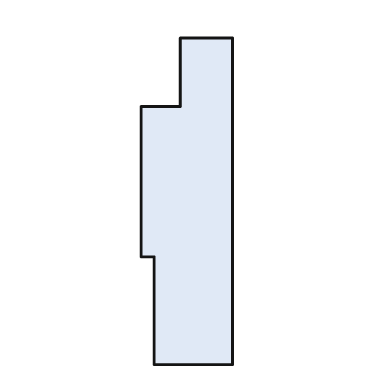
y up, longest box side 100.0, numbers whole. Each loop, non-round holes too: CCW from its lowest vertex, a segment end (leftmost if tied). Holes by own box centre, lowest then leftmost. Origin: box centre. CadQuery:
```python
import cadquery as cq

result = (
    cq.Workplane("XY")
    .moveTo(-10.0, -50.0)
    .lineTo(14.0, -50.0)
    .lineTo(14.0, 50.0)
    .lineTo(-2.0, 50.0)
    .lineTo(-2.0, 29.0)
    .lineTo(-14.0, 29.0)
    .lineTo(-14.0, -17.0)
    .lineTo(-10.0, -17.0)
    .close()
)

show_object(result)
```